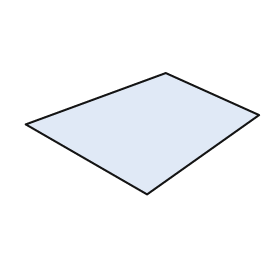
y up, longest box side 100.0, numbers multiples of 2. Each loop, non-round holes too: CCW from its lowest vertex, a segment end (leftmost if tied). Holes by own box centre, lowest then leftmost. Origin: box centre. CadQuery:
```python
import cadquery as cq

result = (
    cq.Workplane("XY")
    .moveTo(2.0, -26.0)
    .lineTo(50.0, 8.0)
    .lineTo(10.0, 26.0)
    .lineTo(-50.0, 4.0)
    .close()
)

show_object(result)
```